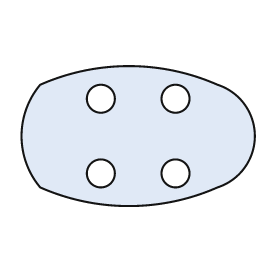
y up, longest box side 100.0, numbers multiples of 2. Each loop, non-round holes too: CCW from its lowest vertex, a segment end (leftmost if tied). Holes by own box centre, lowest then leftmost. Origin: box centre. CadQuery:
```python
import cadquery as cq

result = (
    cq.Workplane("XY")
    .moveTo(-42.0, -22.0)
    .threePointArc((-4.0, -30.0), (34.0, -22.0))
    .threePointArc((50.0, 0.0), (34.0, 22.0))
    .threePointArc((-4.0, 30.0), (-42.0, 22.0))
    .threePointArc((-50.0, 0.0), (-42.0, -22.0))
    .close()
    .moveTo(-16.0, -16.0)
    .circle(6.0)
    .moveTo(16.0, -16.0)
    .circle(6.0)
    .moveTo(-16.0, 16.0)
    .circle(6.0)
    .moveTo(16.0, 16.0)
    .circle(6.0)
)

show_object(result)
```